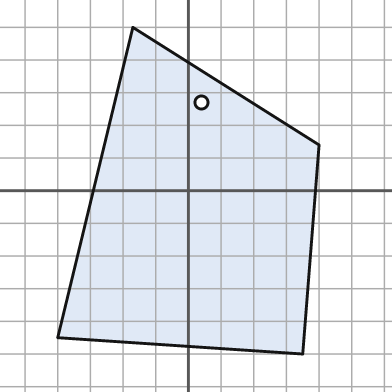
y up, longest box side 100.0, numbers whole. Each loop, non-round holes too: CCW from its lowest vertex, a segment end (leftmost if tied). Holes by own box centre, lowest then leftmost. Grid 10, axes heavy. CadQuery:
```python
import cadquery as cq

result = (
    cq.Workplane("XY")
    .moveTo(35.0, -50.0)
    .lineTo(40.0, 14.0)
    .lineTo(-17.0, 50.0)
    .lineTo(-40.0, -45.0)
    .close()
    .moveTo(4.0, 27.0)
    .circle(2.0)
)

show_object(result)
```